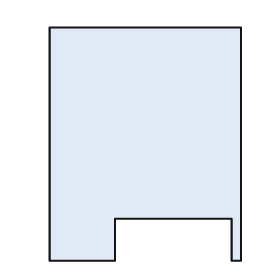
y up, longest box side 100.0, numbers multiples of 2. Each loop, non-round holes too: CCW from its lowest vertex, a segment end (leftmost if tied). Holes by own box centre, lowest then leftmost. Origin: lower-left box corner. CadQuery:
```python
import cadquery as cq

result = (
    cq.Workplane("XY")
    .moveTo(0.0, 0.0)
    .lineTo(28.0, 0.0)
    .lineTo(28.0, 18.0)
    .lineTo(78.0, 18.0)
    .lineTo(78.0, 0.0)
    .lineTo(82.0, 0.0)
    .lineTo(82.0, 100.0)
    .lineTo(0.0, 100.0)
    .close()
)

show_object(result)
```